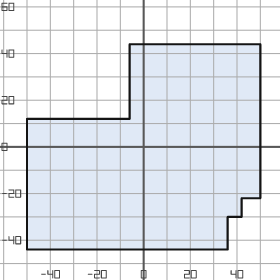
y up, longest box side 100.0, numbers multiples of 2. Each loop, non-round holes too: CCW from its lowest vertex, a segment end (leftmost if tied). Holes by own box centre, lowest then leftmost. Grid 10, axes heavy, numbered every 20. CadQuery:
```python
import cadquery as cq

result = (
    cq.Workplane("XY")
    .moveTo(-50.0, -44.0)
    .lineTo(36.0, -44.0)
    .lineTo(36.0, -30.0)
    .lineTo(42.0, -30.0)
    .lineTo(42.0, -22.0)
    .lineTo(50.0, -22.0)
    .lineTo(50.0, 44.0)
    .lineTo(-6.0, 44.0)
    .lineTo(-6.0, 12.0)
    .lineTo(-50.0, 12.0)
    .close()
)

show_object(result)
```